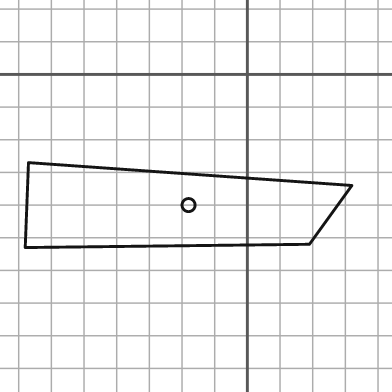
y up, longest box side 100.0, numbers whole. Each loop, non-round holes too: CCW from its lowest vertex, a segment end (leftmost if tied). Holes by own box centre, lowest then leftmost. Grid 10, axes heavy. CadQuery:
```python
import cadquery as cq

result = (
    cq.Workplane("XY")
    .moveTo(-68.0, -53.0)
    .lineTo(19.0, -52.0)
    .lineTo(32.0, -34.0)
    .lineTo(-67.0, -27.0)
    .close()
    .moveTo(-18.0, -40.0)
    .circle(2.0)
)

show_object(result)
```